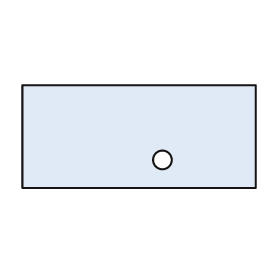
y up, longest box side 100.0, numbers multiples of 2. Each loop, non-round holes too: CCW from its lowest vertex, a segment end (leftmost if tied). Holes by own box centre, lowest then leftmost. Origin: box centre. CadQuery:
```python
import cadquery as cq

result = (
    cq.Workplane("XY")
    .moveTo(-50.0, -22.0)
    .lineTo(50.0, -22.0)
    .lineTo(50.0, 22.0)
    .lineTo(-50.0, 22.0)
    .close()
    .moveTo(10.0, -10.0)
    .circle(4.0)
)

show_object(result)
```